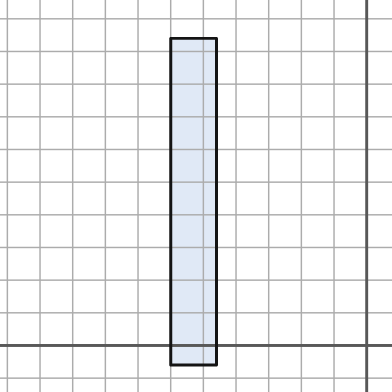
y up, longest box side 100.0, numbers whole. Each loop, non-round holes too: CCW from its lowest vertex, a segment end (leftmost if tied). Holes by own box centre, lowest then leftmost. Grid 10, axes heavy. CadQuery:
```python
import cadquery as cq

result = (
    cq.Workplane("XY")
    .moveTo(-60.0, -6.0)
    .lineTo(-46.0, -6.0)
    .lineTo(-46.0, 94.0)
    .lineTo(-60.0, 94.0)
    .close()
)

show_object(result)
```